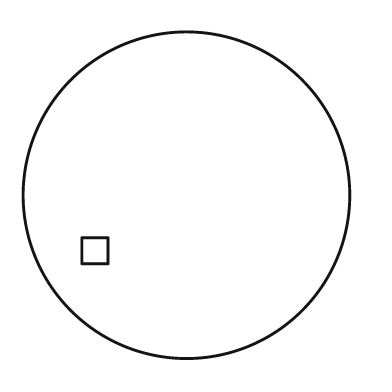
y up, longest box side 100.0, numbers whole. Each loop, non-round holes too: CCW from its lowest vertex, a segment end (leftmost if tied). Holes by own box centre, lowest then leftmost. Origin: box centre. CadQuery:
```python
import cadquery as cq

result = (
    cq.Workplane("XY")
    .moveTo(0.0, 0.0)
    .circle(50.0)
    .moveTo(-32.0, -21.0)
    .lineTo(-24.0, -21.0)
    .lineTo(-24.0, -13.0)
    .lineTo(-32.0, -13.0)
    .close()
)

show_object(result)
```